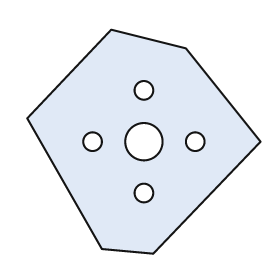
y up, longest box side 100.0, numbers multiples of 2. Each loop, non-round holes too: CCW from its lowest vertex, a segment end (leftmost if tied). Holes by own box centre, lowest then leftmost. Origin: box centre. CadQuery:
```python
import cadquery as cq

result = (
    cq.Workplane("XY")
    .moveTo(4.0, -48.0)
    .lineTo(50.0, 0.0)
    .lineTo(18.0, 40.0)
    .lineTo(-14.0, 48.0)
    .lineTo(-50.0, 10.0)
    .lineTo(-18.0, -46.0)
    .close()
    .moveTo(0.0, -22.0)
    .circle(4.0)
    .moveTo(-22.0, 0.0)
    .circle(4.0)
    .moveTo(0.0, 0.0)
    .circle(8.0)
    .moveTo(22.0, 0.0)
    .circle(4.0)
    .moveTo(0.0, 22.0)
    .circle(4.0)
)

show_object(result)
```